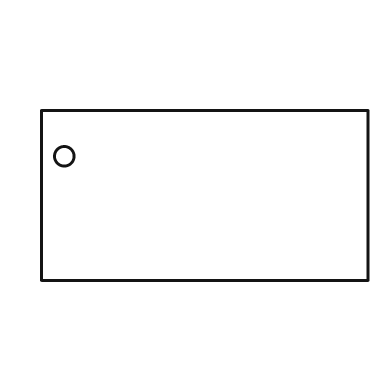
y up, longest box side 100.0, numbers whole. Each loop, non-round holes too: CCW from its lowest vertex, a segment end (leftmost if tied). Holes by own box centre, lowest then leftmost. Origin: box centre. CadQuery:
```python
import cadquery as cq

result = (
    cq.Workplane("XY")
    .moveTo(-50.0, -26.0)
    .lineTo(50.0, -26.0)
    .lineTo(50.0, 26.0)
    .lineTo(-50.0, 26.0)
    .close()
    .moveTo(-43.0, 12.0)
    .circle(3.0)
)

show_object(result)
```